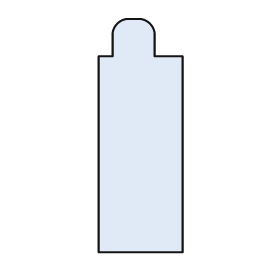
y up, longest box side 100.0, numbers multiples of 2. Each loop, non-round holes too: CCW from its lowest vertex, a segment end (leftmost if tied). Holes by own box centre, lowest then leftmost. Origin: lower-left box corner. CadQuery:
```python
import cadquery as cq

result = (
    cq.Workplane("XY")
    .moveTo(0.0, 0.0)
    .lineTo(36.0, 0.0)
    .lineTo(36.0, 84.0)
    .lineTo(24.0, 84.0)
    .lineTo(24.0, 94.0)
    .threePointArc((22.0, 98.0), (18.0, 100.0))
    .lineTo(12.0, 100.0)
    .threePointArc((8.0, 98.0), (6.0, 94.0))
    .lineTo(6.0, 84.0)
    .lineTo(0.0, 84.0)
    .close()
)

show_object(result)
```